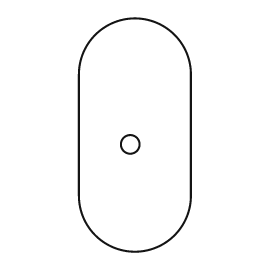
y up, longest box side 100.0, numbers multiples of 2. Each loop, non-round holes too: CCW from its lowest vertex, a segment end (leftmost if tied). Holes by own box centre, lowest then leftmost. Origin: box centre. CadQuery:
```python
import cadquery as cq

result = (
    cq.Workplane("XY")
    .moveTo(-24.0, -26.0)
    .threePointArc((0.0, -50.0), (24.0, -26.0))
    .lineTo(24.0, 26.0)
    .threePointArc((0.0, 50.0), (-24.0, 26.0))
    .close()
    .moveTo(-2.0, -4.0)
    .circle(4.0)
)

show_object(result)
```